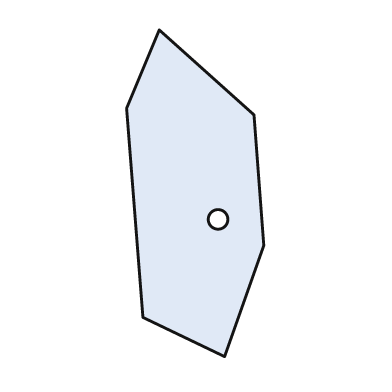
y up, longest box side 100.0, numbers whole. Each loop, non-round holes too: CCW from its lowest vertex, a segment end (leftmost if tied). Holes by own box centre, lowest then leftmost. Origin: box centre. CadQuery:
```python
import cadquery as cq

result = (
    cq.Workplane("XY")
    .moveTo(9.0, -50.0)
    .lineTo(21.0, -16.0)
    .lineTo(18.0, 24.0)
    .lineTo(-11.0, 50.0)
    .lineTo(-21.0, 26.0)
    .lineTo(-16.0, -38.0)
    .close()
    .moveTo(7.0, -8.0)
    .circle(3.0)
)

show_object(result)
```